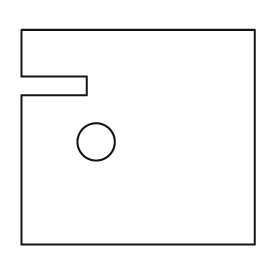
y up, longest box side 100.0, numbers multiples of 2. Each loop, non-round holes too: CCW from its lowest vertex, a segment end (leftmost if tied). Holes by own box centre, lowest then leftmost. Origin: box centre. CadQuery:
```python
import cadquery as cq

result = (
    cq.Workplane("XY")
    .moveTo(-50.0, -46.0)
    .lineTo(50.0, -46.0)
    .lineTo(50.0, 46.0)
    .lineTo(-50.0, 46.0)
    .lineTo(-50.0, 26.0)
    .lineTo(-22.0, 26.0)
    .lineTo(-22.0, 18.0)
    .lineTo(-50.0, 18.0)
    .close()
    .moveTo(-18.0, -2.0)
    .circle(8.0)
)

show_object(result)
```